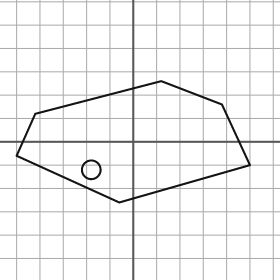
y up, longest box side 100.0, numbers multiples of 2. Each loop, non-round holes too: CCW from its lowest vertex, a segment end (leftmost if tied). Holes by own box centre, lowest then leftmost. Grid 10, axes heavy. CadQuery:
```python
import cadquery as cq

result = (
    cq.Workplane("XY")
    .moveTo(-6.0, -26.0)
    .lineTo(50.0, -10.0)
    .lineTo(38.0, 16.0)
    .lineTo(12.0, 26.0)
    .lineTo(-42.0, 12.0)
    .lineTo(-50.0, -6.0)
    .close()
    .moveTo(-18.0, -12.0)
    .circle(4.0)
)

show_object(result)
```